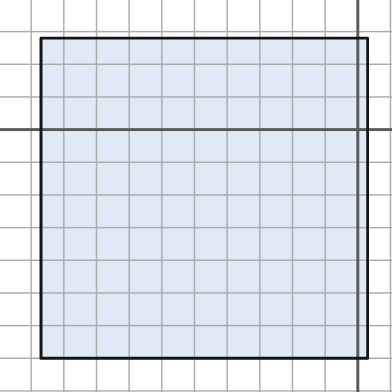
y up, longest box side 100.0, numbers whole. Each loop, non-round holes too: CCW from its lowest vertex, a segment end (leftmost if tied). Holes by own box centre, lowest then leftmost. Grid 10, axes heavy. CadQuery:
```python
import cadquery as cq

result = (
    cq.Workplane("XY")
    .moveTo(-97.0, -70.0)
    .lineTo(3.0, -70.0)
    .lineTo(3.0, 28.0)
    .lineTo(-97.0, 28.0)
    .close()
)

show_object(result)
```